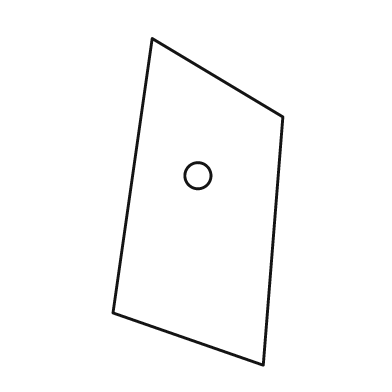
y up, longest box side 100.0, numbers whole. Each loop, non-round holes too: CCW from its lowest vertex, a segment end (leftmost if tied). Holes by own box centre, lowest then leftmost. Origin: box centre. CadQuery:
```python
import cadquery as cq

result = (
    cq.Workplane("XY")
    .moveTo(20.0, -50.0)
    .lineTo(26.0, 26.0)
    .lineTo(-14.0, 50.0)
    .lineTo(-26.0, -34.0)
    .close()
    .moveTo(0.0, 8.0)
    .circle(4.0)
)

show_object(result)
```